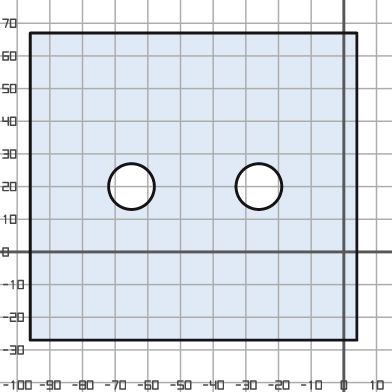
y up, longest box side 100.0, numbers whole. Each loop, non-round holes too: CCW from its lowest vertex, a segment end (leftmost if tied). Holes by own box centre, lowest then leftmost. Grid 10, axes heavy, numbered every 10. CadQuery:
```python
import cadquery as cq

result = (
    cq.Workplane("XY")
    .moveTo(-96.0, -27.0)
    .lineTo(4.0, -27.0)
    .lineTo(4.0, 67.0)
    .lineTo(-96.0, 67.0)
    .close()
    .moveTo(-65.0, 20.0)
    .circle(7.0)
    .moveTo(-26.0, 20.0)
    .circle(7.0)
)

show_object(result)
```